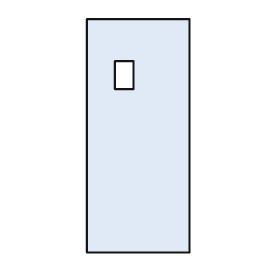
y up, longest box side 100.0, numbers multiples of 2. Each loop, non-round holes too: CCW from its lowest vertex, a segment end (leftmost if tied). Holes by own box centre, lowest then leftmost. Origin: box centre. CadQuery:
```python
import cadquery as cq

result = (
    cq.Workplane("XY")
    .moveTo(-22.0, -50.0)
    .lineTo(22.0, -50.0)
    .lineTo(22.0, 50.0)
    .lineTo(-22.0, 50.0)
    .close()
    .moveTo(-10.0, 20.0)
    .lineTo(-2.0, 20.0)
    .lineTo(-2.0, 32.0)
    .lineTo(-10.0, 32.0)
    .close()
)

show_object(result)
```